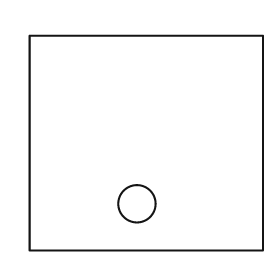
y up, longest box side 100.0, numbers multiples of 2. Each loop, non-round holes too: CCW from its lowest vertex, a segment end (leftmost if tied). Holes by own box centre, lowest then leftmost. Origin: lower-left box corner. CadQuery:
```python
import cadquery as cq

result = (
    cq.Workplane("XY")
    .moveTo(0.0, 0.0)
    .lineTo(100.0, 0.0)
    .lineTo(100.0, 92.0)
    .lineTo(0.0, 92.0)
    .close()
    .moveTo(46.0, 20.0)
    .circle(8.0)
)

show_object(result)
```